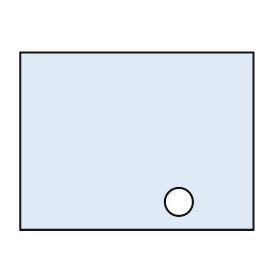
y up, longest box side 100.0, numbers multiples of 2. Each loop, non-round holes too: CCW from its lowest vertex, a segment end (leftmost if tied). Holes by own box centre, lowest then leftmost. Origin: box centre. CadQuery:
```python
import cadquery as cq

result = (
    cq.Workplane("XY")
    .moveTo(-50.0, -38.0)
    .lineTo(50.0, -38.0)
    .lineTo(50.0, 38.0)
    .lineTo(-50.0, 38.0)
    .close()
    .moveTo(18.0, -26.0)
    .circle(6.0)
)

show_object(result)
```